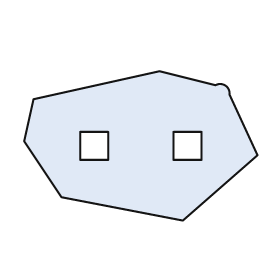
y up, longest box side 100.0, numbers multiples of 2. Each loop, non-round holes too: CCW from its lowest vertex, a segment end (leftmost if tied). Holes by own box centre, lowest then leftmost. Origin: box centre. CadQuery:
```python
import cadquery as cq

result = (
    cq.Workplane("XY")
    .moveTo(18.0, -32.0)
    .lineTo(50.0, -4.0)
    .lineTo(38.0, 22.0)
    .threePointArc((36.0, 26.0), (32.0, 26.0))
    .lineTo(8.0, 32.0)
    .lineTo(-46.0, 20.0)
    .lineTo(-50.0, 2.0)
    .lineTo(-34.0, -22.0)
    .close()
    .moveTo(-26.0, -6.0)
    .lineTo(-14.0, -6.0)
    .lineTo(-14.0, 6.0)
    .lineTo(-26.0, 6.0)
    .close()
    .moveTo(14.0, -6.0)
    .lineTo(26.0, -6.0)
    .lineTo(26.0, 6.0)
    .lineTo(14.0, 6.0)
    .close()
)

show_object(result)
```